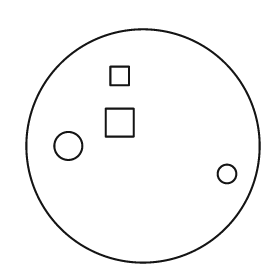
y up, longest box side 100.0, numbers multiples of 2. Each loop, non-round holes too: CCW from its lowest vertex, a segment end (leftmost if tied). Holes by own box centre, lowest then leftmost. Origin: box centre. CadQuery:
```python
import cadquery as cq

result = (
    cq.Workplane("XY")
    .moveTo(0.0, 0.0)
    .circle(50.0)
    .moveTo(36.0, -12.0)
    .circle(4.0)
    .moveTo(-32.0, 0.0)
    .circle(6.0)
    .moveTo(-16.0, 4.0)
    .lineTo(-4.0, 4.0)
    .lineTo(-4.0, 16.0)
    .lineTo(-16.0, 16.0)
    .close()
    .moveTo(-14.0, 26.0)
    .lineTo(-6.0, 26.0)
    .lineTo(-6.0, 34.0)
    .lineTo(-14.0, 34.0)
    .close()
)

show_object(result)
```